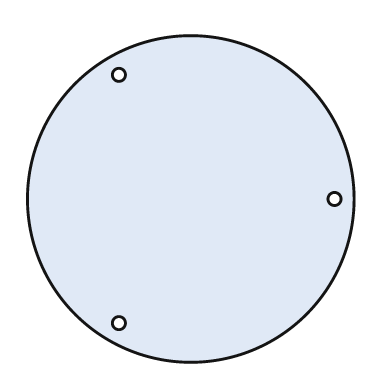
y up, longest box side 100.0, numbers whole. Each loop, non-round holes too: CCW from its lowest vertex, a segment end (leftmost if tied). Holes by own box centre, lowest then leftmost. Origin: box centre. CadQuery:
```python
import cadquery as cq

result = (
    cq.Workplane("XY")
    .moveTo(0.0, 0.0)
    .circle(50.0)
    .moveTo(-22.0, -38.0)
    .circle(2.0)
    .moveTo(44.0, 0.0)
    .circle(2.0)
    .moveTo(-22.0, 38.0)
    .circle(2.0)
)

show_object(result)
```